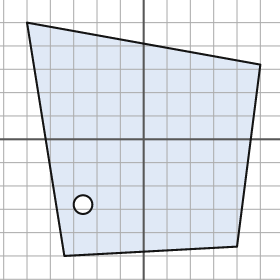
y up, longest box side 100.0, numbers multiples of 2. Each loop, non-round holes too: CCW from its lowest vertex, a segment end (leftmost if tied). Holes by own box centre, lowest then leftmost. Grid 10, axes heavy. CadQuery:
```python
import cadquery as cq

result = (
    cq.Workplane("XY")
    .moveTo(-34.0, -50.0)
    .lineTo(40.0, -46.0)
    .lineTo(50.0, 32.0)
    .lineTo(-50.0, 50.0)
    .close()
    .moveTo(-26.0, -28.0)
    .circle(4.0)
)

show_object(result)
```